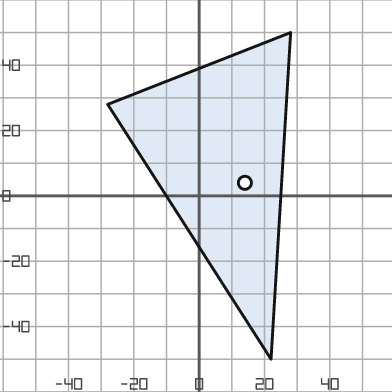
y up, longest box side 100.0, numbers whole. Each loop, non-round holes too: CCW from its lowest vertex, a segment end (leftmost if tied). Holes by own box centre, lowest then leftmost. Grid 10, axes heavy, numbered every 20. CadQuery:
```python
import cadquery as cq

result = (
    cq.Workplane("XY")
    .moveTo(22.0, -50.0)
    .lineTo(28.0, 50.0)
    .lineTo(-28.0, 28.0)
    .close()
    .moveTo(14.0, 4.0)
    .circle(2.0)
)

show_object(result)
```